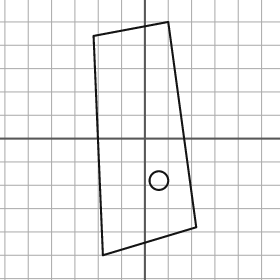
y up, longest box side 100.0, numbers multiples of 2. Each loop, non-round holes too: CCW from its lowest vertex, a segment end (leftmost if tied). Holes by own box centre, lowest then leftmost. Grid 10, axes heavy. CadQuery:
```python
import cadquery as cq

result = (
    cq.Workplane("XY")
    .moveTo(-18.0, -50.0)
    .lineTo(22.0, -38.0)
    .lineTo(10.0, 50.0)
    .lineTo(-22.0, 44.0)
    .close()
    .moveTo(6.0, -18.0)
    .circle(4.0)
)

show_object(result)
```